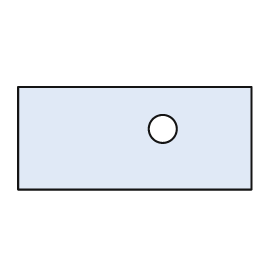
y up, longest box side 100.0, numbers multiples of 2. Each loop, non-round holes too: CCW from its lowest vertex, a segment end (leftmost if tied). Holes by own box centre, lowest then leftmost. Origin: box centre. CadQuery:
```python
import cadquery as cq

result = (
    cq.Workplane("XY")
    .moveTo(-50.0, -22.0)
    .lineTo(50.0, -22.0)
    .lineTo(50.0, 22.0)
    .lineTo(-50.0, 22.0)
    .close()
    .moveTo(12.0, 4.0)
    .circle(6.0)
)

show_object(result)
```